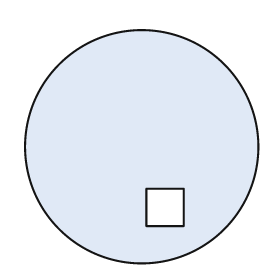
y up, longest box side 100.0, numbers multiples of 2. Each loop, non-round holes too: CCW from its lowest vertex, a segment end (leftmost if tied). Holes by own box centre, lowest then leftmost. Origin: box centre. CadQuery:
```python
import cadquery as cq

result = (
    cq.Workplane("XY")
    .moveTo(0.0, 0.0)
    .circle(50.0)
    .moveTo(2.0, -34.0)
    .lineTo(18.0, -34.0)
    .lineTo(18.0, -18.0)
    .lineTo(2.0, -18.0)
    .close()
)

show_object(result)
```